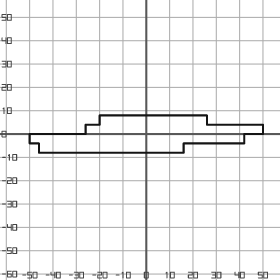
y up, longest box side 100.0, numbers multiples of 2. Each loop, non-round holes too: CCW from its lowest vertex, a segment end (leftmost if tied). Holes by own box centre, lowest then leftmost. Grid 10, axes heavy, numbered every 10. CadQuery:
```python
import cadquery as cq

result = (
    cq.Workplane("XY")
    .moveTo(-46.0, -8.0)
    .lineTo(16.0, -8.0)
    .lineTo(16.0, -4.0)
    .lineTo(42.0, -4.0)
    .lineTo(42.0, 0.0)
    .lineTo(50.0, 0.0)
    .lineTo(50.0, 4.0)
    .lineTo(26.0, 4.0)
    .lineTo(26.0, 8.0)
    .lineTo(-20.0, 8.0)
    .lineTo(-20.0, 4.0)
    .lineTo(-26.0, 4.0)
    .lineTo(-26.0, 0.0)
    .lineTo(-50.0, 0.0)
    .lineTo(-50.0, -4.0)
    .lineTo(-46.0, -4.0)
    .close()
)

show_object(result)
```